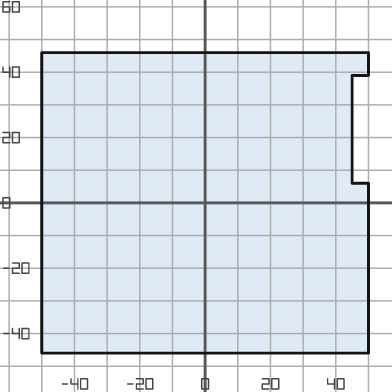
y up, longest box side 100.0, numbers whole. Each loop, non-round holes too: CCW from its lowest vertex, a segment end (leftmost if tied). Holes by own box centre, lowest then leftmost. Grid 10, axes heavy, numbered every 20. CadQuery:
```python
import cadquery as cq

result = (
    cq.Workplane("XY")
    .moveTo(-50.0, -46.0)
    .lineTo(50.0, -46.0)
    .lineTo(50.0, 6.0)
    .lineTo(45.0, 6.0)
    .lineTo(45.0, 39.0)
    .lineTo(50.0, 39.0)
    .lineTo(50.0, 46.0)
    .lineTo(-50.0, 46.0)
    .close()
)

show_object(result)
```